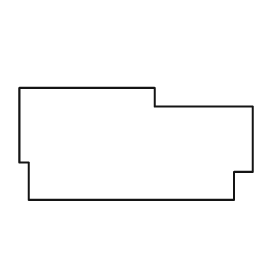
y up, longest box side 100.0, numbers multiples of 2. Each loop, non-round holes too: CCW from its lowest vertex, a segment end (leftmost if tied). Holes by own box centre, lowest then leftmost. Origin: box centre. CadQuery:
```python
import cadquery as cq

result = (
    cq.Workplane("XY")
    .moveTo(-46.0, -24.0)
    .lineTo(42.0, -24.0)
    .lineTo(42.0, -12.0)
    .lineTo(50.0, -12.0)
    .lineTo(50.0, 16.0)
    .lineTo(8.0, 16.0)
    .lineTo(8.0, 24.0)
    .lineTo(-50.0, 24.0)
    .lineTo(-50.0, -8.0)
    .lineTo(-46.0, -8.0)
    .close()
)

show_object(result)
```